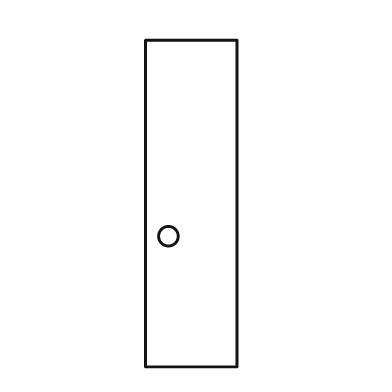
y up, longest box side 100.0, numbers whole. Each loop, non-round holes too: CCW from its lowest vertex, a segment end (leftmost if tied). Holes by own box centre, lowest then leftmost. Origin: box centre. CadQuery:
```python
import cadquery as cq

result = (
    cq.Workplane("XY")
    .moveTo(-14.0, -50.0)
    .lineTo(14.0, -50.0)
    .lineTo(14.0, 50.0)
    .lineTo(-14.0, 50.0)
    .close()
    .moveTo(-7.0, -10.0)
    .circle(3.0)
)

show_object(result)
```